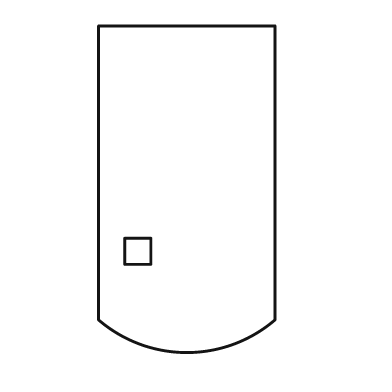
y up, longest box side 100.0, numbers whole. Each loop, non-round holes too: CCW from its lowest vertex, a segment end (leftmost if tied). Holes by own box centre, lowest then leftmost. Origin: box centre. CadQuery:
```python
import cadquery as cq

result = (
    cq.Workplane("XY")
    .moveTo(-27.0, -40.0)
    .threePointArc((0.0, -50.0), (27.0, -40.0))
    .lineTo(27.0, 50.0)
    .lineTo(-27.0, 50.0)
    .close()
    .moveTo(-19.0, -23.0)
    .lineTo(-11.0, -23.0)
    .lineTo(-11.0, -15.0)
    .lineTo(-19.0, -15.0)
    .close()
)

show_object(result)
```